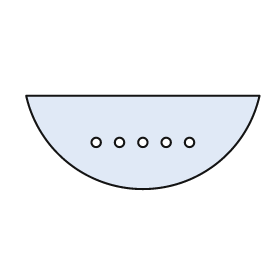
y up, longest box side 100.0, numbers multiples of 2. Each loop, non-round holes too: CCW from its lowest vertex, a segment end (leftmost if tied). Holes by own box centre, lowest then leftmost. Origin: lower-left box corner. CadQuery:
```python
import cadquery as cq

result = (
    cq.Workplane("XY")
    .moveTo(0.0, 40.0)
    .threePointArc((50.0, 0.0), (100.0, 40.0))
    .close()
    .moveTo(30.0, 20.0)
    .circle(2.0)
    .moveTo(40.0, 20.0)
    .circle(2.0)
    .moveTo(50.0, 20.0)
    .circle(2.0)
    .moveTo(60.0, 20.0)
    .circle(2.0)
    .moveTo(70.0, 20.0)
    .circle(2.0)
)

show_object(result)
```